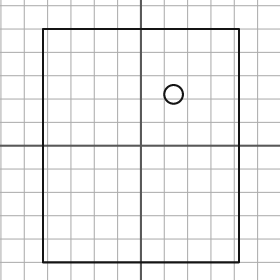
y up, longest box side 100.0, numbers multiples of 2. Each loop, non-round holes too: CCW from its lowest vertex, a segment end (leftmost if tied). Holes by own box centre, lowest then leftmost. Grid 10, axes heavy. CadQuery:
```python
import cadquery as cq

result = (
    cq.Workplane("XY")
    .moveTo(-42.0, -50.0)
    .lineTo(42.0, -50.0)
    .lineTo(42.0, 50.0)
    .lineTo(-42.0, 50.0)
    .close()
    .moveTo(14.0, 22.0)
    .circle(4.0)
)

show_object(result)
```